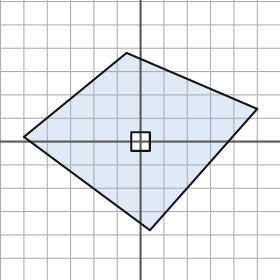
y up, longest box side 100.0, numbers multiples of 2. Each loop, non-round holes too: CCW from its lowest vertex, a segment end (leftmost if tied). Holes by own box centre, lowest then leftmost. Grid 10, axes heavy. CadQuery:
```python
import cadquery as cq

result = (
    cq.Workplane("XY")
    .moveTo(4.0, -38.0)
    .lineTo(50.0, 14.0)
    .lineTo(-6.0, 38.0)
    .lineTo(-50.0, 2.0)
    .close()
    .moveTo(-4.0, -4.0)
    .lineTo(4.0, -4.0)
    .lineTo(4.0, 4.0)
    .lineTo(-4.0, 4.0)
    .close()
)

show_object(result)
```